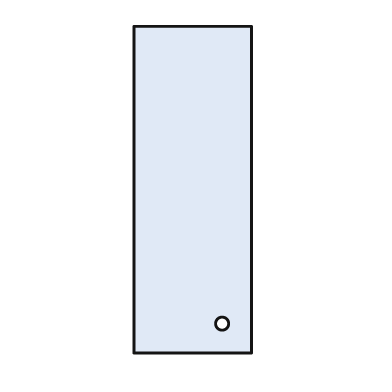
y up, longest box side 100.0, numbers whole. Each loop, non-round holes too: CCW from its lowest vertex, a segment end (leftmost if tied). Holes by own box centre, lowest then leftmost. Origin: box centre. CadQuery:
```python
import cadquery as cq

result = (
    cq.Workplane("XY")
    .moveTo(-18.0, -50.0)
    .lineTo(18.0, -50.0)
    .lineTo(18.0, 50.0)
    .lineTo(-18.0, 50.0)
    .close()
    .moveTo(9.0, -41.0)
    .circle(2.0)
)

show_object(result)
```